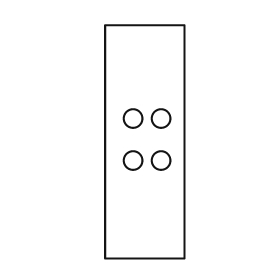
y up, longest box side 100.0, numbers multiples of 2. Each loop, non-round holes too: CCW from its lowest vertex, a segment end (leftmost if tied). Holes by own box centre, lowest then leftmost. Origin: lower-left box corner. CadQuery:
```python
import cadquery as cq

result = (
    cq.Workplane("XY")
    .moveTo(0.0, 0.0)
    .lineTo(34.0, 0.0)
    .lineTo(34.0, 100.0)
    .lineTo(0.0, 100.0)
    .close()
    .moveTo(12.0, 42.0)
    .circle(4.0)
    .moveTo(24.0, 42.0)
    .circle(4.0)
    .moveTo(12.0, 60.0)
    .circle(4.0)
    .moveTo(24.0, 60.0)
    .circle(4.0)
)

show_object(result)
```